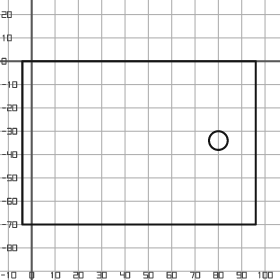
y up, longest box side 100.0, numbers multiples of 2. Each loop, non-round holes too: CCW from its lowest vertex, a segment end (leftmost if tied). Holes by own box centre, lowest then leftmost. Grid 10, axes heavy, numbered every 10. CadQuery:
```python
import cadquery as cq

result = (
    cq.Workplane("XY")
    .moveTo(-4.0, -70.0)
    .lineTo(96.0, -70.0)
    .lineTo(96.0, 0.0)
    .lineTo(-4.0, 0.0)
    .close()
    .moveTo(80.0, -34.0)
    .circle(4.0)
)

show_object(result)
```